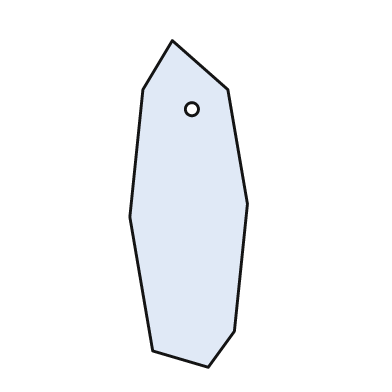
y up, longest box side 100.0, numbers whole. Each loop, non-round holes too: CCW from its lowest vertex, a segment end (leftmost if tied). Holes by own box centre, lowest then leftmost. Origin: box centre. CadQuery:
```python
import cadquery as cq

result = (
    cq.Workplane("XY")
    .moveTo(6.0, -50.0)
    .lineTo(14.0, -39.0)
    .lineTo(18.0, 0.0)
    .lineTo(12.0, 35.0)
    .lineTo(-5.0, 50.0)
    .lineTo(-14.0, 35.0)
    .lineTo(-18.0, -4.0)
    .lineTo(-11.0, -45.0)
    .close()
    .moveTo(1.0, 29.0)
    .circle(2.0)
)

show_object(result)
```